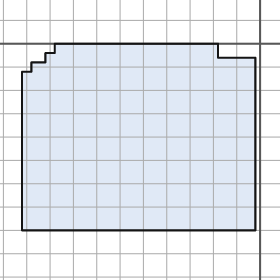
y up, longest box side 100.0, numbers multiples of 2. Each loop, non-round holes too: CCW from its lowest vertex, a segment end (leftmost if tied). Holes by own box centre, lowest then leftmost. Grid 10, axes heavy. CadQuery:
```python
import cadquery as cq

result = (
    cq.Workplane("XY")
    .moveTo(-102.0, -80.0)
    .lineTo(-2.0, -80.0)
    .lineTo(-2.0, -6.0)
    .lineTo(-18.0, -6.0)
    .lineTo(-18.0, 0.0)
    .lineTo(-88.0, 0.0)
    .lineTo(-88.0, -4.0)
    .lineTo(-92.0, -4.0)
    .lineTo(-92.0, -8.0)
    .lineTo(-98.0, -8.0)
    .lineTo(-98.0, -12.0)
    .lineTo(-102.0, -12.0)
    .close()
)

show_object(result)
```